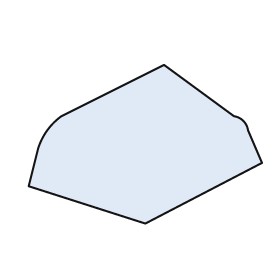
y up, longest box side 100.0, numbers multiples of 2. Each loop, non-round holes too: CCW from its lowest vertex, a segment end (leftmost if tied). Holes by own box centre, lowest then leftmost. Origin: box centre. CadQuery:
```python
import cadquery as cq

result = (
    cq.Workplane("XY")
    .moveTo(0.0, -34.0)
    .lineTo(50.0, -8.0)
    .lineTo(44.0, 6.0)
    .threePointArc((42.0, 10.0), (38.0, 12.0))
    .lineTo(8.0, 34.0)
    .lineTo(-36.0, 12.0)
    .threePointArc((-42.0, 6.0), (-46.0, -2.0))
    .lineTo(-50.0, -18.0)
    .close()
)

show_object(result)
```